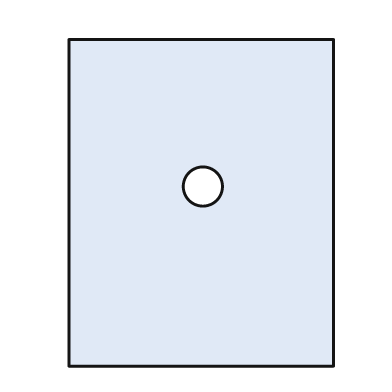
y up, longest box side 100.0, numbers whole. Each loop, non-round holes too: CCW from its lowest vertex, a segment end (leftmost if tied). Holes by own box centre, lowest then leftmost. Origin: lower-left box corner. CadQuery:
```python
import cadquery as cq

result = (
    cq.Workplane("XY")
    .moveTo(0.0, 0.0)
    .lineTo(81.0, 0.0)
    .lineTo(81.0, 100.0)
    .lineTo(0.0, 100.0)
    .close()
    .moveTo(41.0, 55.0)
    .circle(6.0)
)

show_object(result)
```